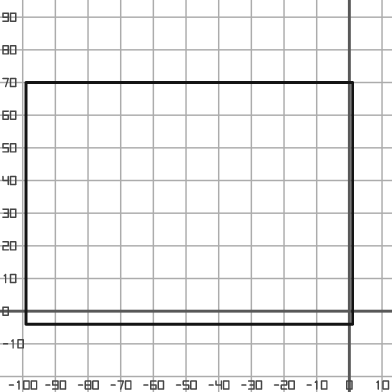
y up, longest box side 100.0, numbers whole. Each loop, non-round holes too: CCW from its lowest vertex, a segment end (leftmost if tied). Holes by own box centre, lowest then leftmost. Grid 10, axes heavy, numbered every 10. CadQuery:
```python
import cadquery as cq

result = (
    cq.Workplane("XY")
    .moveTo(-99.0, -4.0)
    .lineTo(1.0, -4.0)
    .lineTo(1.0, 70.0)
    .lineTo(-99.0, 70.0)
    .close()
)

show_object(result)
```